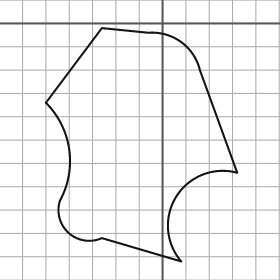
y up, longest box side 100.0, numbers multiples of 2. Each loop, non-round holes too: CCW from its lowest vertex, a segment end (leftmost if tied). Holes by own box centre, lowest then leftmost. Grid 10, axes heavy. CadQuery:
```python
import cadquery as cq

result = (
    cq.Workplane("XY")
    .moveTo(8.0, -102.0)
    .threePointArc((6.0, -74.0), (32.0, -64.0))
    .lineTo(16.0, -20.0)
    .threePointArc((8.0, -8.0), (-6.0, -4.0))
    .lineTo(-26.0, -2.0)
    .lineTo(-50.0, -34.0)
    .threePointArc((-40.0, -54.0), (-44.0, -76.0))
    .threePointArc((-40.0, -90.0), (-26.0, -92.0))
    .close()
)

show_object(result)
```